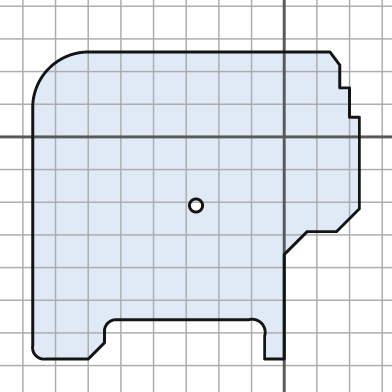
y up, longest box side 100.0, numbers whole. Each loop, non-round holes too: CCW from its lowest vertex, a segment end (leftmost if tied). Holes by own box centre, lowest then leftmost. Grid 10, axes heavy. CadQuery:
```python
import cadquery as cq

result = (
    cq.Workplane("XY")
    .moveTo(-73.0, -68.0)
    .lineTo(-60.0, -68.0)
    .lineTo(-55.0, -63.0)
    .lineTo(-55.0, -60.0)
    .threePointArc((-54.0, -57.0), (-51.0, -56.0))
    .lineTo(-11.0, -56.0)
    .threePointArc((-7.0, -57.0), (-6.0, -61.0))
    .lineTo(-6.0, -68.0)
    .lineTo(0.0, -68.0)
    .lineTo(0.0, -36.0)
    .lineTo(7.0, -29.0)
    .lineTo(16.0, -29.0)
    .lineTo(23.0, -22.0)
    .lineTo(23.0, 6.0)
    .lineTo(20.0, 6.0)
    .lineTo(20.0, 15.0)
    .lineTo(17.0, 15.0)
    .lineTo(17.0, 22.0)
    .lineTo(14.0, 26.0)
    .lineTo(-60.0, 26.0)
    .threePointArc((-72.0, 21.0), (-77.0, 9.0))
    .lineTo(-77.0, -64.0)
    .threePointArc((-76.0, -67.0), (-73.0, -68.0))
    .close()
    .moveTo(-27.0, -21.0)
    .circle(2.0)
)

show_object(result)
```